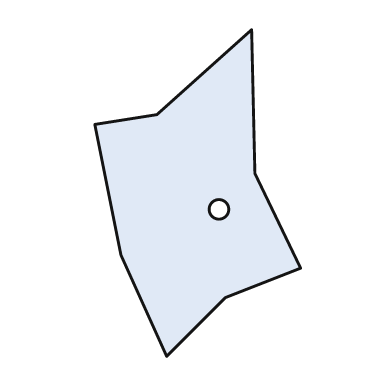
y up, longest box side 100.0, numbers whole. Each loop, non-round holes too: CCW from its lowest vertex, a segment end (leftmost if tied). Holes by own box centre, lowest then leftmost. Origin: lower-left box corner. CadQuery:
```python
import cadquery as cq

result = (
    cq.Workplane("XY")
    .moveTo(22.0, 0.0)
    .lineTo(40.0, 18.0)
    .lineTo(63.0, 27.0)
    .lineTo(49.0, 56.0)
    .lineTo(48.0, 100.0)
    .lineTo(19.0, 74.0)
    .lineTo(0.0, 71.0)
    .lineTo(8.0, 31.0)
    .close()
    .moveTo(38.0, 45.0)
    .circle(3.0)
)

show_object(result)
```